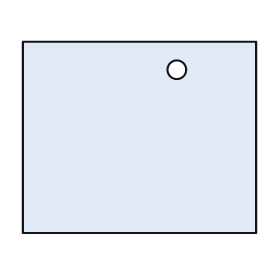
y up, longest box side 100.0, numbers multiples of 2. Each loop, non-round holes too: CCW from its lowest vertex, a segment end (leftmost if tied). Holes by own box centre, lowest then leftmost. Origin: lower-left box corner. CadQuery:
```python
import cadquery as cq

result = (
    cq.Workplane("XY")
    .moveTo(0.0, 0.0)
    .lineTo(100.0, 0.0)
    .lineTo(100.0, 82.0)
    .lineTo(0.0, 82.0)
    .close()
    .moveTo(66.0, 70.0)
    .circle(4.0)
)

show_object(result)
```